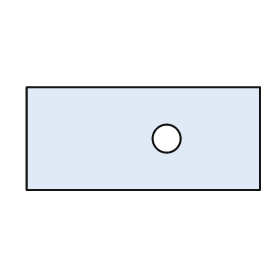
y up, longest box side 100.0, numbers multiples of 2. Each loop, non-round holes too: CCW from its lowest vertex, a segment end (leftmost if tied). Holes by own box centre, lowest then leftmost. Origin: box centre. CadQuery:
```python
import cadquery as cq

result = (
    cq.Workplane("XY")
    .moveTo(-50.0, -22.0)
    .lineTo(50.0, -22.0)
    .lineTo(50.0, 22.0)
    .lineTo(-50.0, 22.0)
    .close()
    .moveTo(10.0, 0.0)
    .circle(6.0)
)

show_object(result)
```